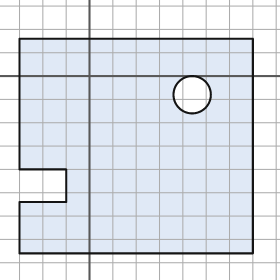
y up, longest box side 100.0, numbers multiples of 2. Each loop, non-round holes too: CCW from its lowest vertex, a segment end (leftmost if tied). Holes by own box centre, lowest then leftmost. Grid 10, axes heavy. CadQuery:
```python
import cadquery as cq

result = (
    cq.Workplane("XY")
    .moveTo(-30.0, -76.0)
    .lineTo(70.0, -76.0)
    .lineTo(70.0, 16.0)
    .lineTo(-30.0, 16.0)
    .lineTo(-30.0, -40.0)
    .lineTo(-10.0, -40.0)
    .lineTo(-10.0, -54.0)
    .lineTo(-30.0, -54.0)
    .close()
    .moveTo(44.0, -8.0)
    .circle(8.0)
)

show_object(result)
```